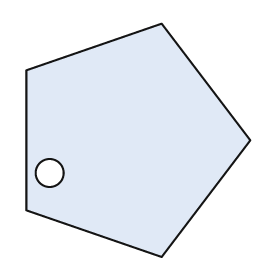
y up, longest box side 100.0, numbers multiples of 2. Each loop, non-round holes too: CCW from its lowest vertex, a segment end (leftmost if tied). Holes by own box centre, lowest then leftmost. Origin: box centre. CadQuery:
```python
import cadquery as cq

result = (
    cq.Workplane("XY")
    .moveTo(10.0, -50.0)
    .lineTo(48.0, 0.0)
    .lineTo(10.0, 50.0)
    .lineTo(-48.0, 30.0)
    .lineTo(-48.0, -30.0)
    .close()
    .moveTo(-38.0, -14.0)
    .circle(6.0)
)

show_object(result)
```